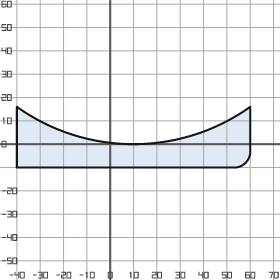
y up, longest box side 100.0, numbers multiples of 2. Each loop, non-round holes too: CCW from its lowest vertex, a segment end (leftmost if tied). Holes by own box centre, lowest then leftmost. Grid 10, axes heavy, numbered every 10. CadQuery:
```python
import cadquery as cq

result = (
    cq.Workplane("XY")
    .moveTo(-40.0, -10.0)
    .lineTo(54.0, -10.0)
    .threePointArc((58.0, -8.0), (60.0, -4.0))
    .lineTo(60.0, 16.0)
    .threePointArc((10.0, 0.0), (-40.0, 16.0))
    .close()
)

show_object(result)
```